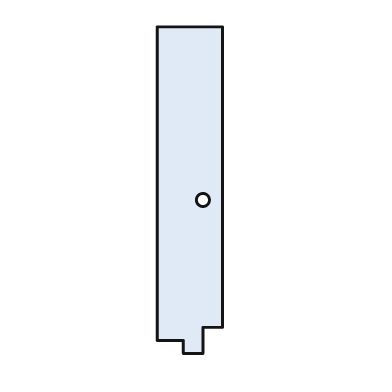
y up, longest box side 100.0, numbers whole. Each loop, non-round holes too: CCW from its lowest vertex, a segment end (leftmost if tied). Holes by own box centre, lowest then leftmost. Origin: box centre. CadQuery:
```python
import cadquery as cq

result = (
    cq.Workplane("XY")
    .moveTo(-2.0, -50.0)
    .lineTo(4.0, -50.0)
    .lineTo(4.0, -42.0)
    .lineTo(10.0, -42.0)
    .lineTo(10.0, 50.0)
    .lineTo(-10.0, 50.0)
    .lineTo(-10.0, -46.0)
    .lineTo(-2.0, -46.0)
    .close()
    .moveTo(4.0, -3.0)
    .circle(2.0)
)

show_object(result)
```